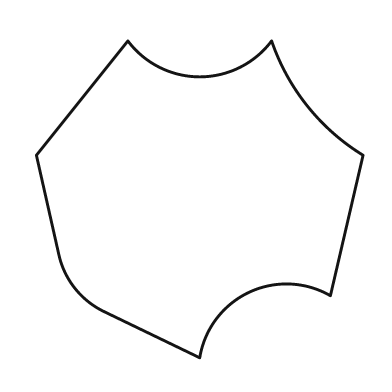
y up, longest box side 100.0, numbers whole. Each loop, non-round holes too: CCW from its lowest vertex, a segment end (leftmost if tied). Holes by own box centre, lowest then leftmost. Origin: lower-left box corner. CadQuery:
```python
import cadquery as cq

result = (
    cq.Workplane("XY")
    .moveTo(50.0, 0.0)
    .threePointArc((65.0, 20.0), (90.0, 19.0))
    .lineTo(100.0, 62.0)
    .threePointArc((83.0, 77.0), (72.0, 97.0))
    .threePointArc((50.0, 86.0), (28.0, 97.0))
    .lineTo(0.0, 62.0)
    .lineTo(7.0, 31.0)
    .threePointArc((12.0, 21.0), (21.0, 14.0))
    .close()
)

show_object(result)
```